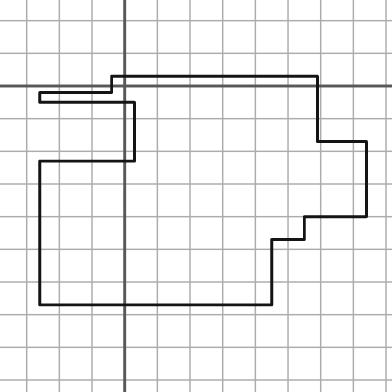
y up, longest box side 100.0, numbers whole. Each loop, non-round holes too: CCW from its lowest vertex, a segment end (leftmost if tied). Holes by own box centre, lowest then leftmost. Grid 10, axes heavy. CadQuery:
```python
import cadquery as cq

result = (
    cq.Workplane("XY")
    .moveTo(-26.0, -67.0)
    .lineTo(45.0, -67.0)
    .lineTo(45.0, -47.0)
    .lineTo(55.0, -47.0)
    .lineTo(55.0, -40.0)
    .lineTo(74.0, -40.0)
    .lineTo(74.0, -17.0)
    .lineTo(59.0, -17.0)
    .lineTo(59.0, 3.0)
    .lineTo(-4.0, 3.0)
    .lineTo(-4.0, -2.0)
    .lineTo(-26.0, -2.0)
    .lineTo(-26.0, -5.0)
    .lineTo(3.0, -5.0)
    .lineTo(3.0, -23.0)
    .lineTo(-26.0, -23.0)
    .close()
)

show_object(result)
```